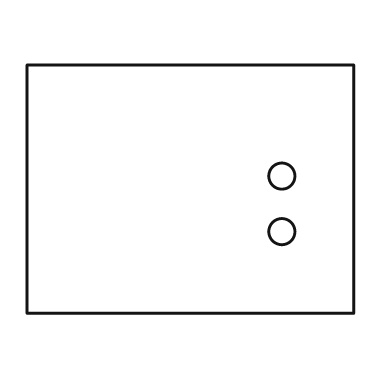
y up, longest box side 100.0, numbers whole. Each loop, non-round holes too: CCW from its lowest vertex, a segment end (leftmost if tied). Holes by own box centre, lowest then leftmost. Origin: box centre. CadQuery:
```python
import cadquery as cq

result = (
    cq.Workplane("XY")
    .moveTo(-50.0, -38.0)
    .lineTo(50.0, -38.0)
    .lineTo(50.0, 38.0)
    .lineTo(-50.0, 38.0)
    .close()
    .moveTo(28.0, -13.0)
    .circle(4.0)
    .moveTo(28.0, 4.0)
    .circle(4.0)
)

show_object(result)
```